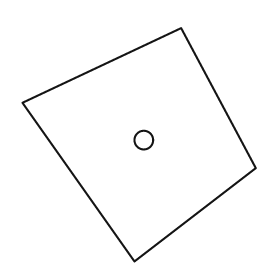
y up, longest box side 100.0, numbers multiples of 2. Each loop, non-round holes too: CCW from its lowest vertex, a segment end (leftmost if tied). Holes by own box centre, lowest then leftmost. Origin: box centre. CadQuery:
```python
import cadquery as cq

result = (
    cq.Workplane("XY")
    .moveTo(-2.0, -50.0)
    .lineTo(50.0, -10.0)
    .lineTo(18.0, 50.0)
    .lineTo(-50.0, 18.0)
    .close()
    .moveTo(2.0, 2.0)
    .circle(4.0)
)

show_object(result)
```